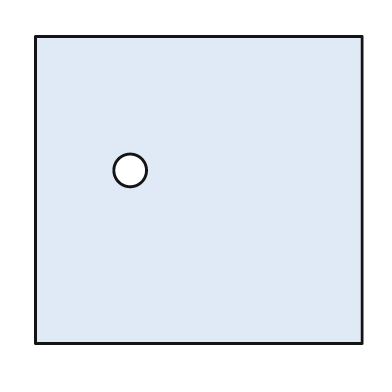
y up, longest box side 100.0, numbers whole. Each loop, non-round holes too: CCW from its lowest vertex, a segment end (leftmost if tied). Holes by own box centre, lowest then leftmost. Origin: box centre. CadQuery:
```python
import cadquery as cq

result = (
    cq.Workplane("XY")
    .moveTo(-50.0, -47.0)
    .lineTo(50.0, -47.0)
    .lineTo(50.0, 47.0)
    .lineTo(-50.0, 47.0)
    .close()
    .moveTo(-21.0, 6.0)
    .circle(5.0)
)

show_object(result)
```